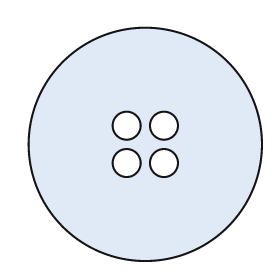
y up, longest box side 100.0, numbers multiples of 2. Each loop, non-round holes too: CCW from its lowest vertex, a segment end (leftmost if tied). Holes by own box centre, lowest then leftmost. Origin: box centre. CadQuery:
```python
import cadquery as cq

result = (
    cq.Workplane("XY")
    .moveTo(0.0, 0.0)
    .circle(50.0)
    .moveTo(-8.0, -8.0)
    .circle(6.0)
    .moveTo(8.0, -8.0)
    .circle(6.0)
    .moveTo(-8.0, 8.0)
    .circle(6.0)
    .moveTo(8.0, 8.0)
    .circle(6.0)
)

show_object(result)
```